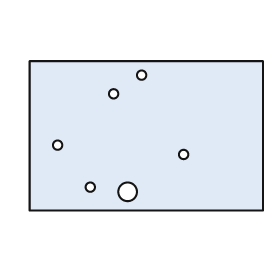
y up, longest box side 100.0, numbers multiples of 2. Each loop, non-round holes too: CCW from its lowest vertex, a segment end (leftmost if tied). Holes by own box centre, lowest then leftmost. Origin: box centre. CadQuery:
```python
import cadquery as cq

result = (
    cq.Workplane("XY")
    .moveTo(-50.0, -32.0)
    .lineTo(50.0, -32.0)
    .lineTo(50.0, 32.0)
    .lineTo(-50.0, 32.0)
    .close()
    .moveTo(-8.0, -24.0)
    .circle(4.0)
    .moveTo(-24.0, -22.0)
    .circle(2.0)
    .moveTo(16.0, -8.0)
    .circle(2.0)
    .moveTo(-38.0, -4.0)
    .circle(2.0)
    .moveTo(-14.0, 18.0)
    .circle(2.0)
    .moveTo(-2.0, 26.0)
    .circle(2.0)
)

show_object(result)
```